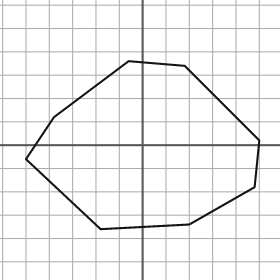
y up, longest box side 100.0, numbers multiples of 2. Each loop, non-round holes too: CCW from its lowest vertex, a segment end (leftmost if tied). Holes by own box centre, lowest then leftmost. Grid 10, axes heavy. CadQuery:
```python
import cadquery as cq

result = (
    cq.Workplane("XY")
    .moveTo(-18.0, -36.0)
    .lineTo(20.0, -34.0)
    .lineTo(48.0, -18.0)
    .lineTo(50.0, 2.0)
    .lineTo(18.0, 34.0)
    .lineTo(-6.0, 36.0)
    .lineTo(-38.0, 12.0)
    .lineTo(-50.0, -6.0)
    .close()
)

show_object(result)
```